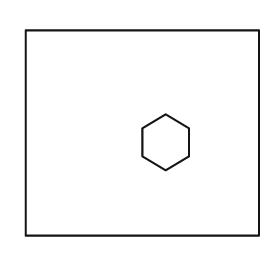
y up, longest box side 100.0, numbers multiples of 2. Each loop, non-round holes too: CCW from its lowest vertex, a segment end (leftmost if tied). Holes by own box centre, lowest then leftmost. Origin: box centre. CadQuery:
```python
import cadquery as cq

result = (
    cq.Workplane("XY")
    .moveTo(-50.0, -44.0)
    .lineTo(50.0, -44.0)
    .lineTo(50.0, 44.0)
    .lineTo(-50.0, 44.0)
    .close()
    .moveTo(10.0, -16.0)
    .lineTo(20.0, -10.0)
    .lineTo(20.0, 2.0)
    .lineTo(10.0, 8.0)
    .lineTo(0.0, 2.0)
    .lineTo(0.0, -10.0)
    .close()
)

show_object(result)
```